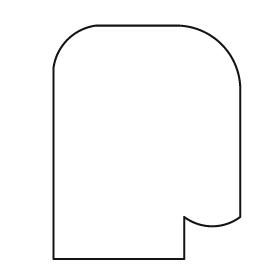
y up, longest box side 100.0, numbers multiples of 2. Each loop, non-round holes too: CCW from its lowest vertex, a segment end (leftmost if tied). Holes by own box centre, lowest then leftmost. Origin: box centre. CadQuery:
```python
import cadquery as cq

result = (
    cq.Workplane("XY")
    .moveTo(-40.0, -50.0)
    .lineTo(16.0, -50.0)
    .lineTo(16.0, -32.0)
    .threePointArc((28.0, -36.0), (40.0, -32.0))
    .lineTo(40.0, 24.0)
    .threePointArc((32.0, 42.0), (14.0, 50.0))
    .lineTo(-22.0, 50.0)
    .threePointArc((-34.0, 44.0), (-40.0, 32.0))
    .close()
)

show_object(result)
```